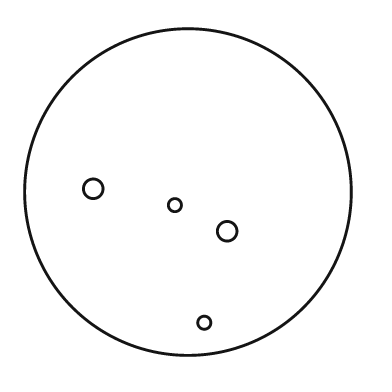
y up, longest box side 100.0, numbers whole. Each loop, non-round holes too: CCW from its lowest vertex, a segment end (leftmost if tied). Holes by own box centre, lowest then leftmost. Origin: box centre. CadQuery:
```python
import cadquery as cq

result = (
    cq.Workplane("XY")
    .moveTo(0.0, 0.0)
    .circle(50.0)
    .moveTo(5.0, -40.0)
    .circle(2.0)
    .moveTo(12.0, -12.0)
    .circle(3.0)
    .moveTo(-4.0, -4.0)
    .circle(2.0)
    .moveTo(-29.0, 1.0)
    .circle(3.0)
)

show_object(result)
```